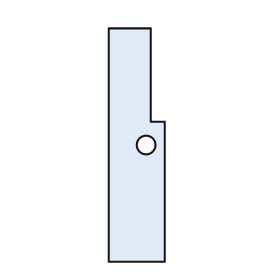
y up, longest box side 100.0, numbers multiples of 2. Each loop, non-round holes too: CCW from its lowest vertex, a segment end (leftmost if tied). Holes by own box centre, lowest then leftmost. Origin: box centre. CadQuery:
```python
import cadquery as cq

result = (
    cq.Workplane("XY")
    .moveTo(-12.0, -50.0)
    .lineTo(12.0, -50.0)
    .lineTo(12.0, 10.0)
    .lineTo(6.0, 10.0)
    .lineTo(6.0, 50.0)
    .lineTo(-12.0, 50.0)
    .close()
    .moveTo(4.0, 0.0)
    .circle(4.0)
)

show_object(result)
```